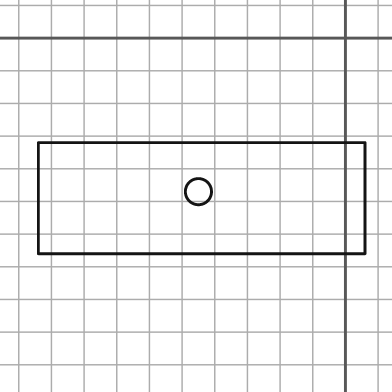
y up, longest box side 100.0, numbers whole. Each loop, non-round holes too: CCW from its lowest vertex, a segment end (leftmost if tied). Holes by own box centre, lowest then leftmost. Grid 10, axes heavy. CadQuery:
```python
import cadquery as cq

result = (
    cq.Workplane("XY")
    .moveTo(-94.0, -66.0)
    .lineTo(6.0, -66.0)
    .lineTo(6.0, -32.0)
    .lineTo(-94.0, -32.0)
    .close()
    .moveTo(-45.0, -47.0)
    .circle(4.0)
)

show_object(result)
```